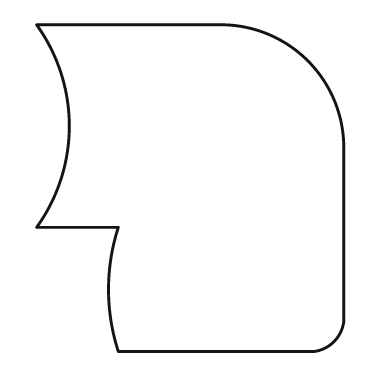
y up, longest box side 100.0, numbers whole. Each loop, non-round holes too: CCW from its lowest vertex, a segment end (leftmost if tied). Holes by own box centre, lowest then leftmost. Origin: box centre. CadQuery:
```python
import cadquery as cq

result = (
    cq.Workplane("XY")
    .moveTo(-22.0, -50.0)
    .lineTo(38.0, -50.0)
    .threePointArc((44.0, -47.0), (47.0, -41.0))
    .lineTo(47.0, 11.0)
    .threePointArc((36.0, 39.0), (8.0, 50.0))
    .lineTo(-47.0, 50.0)
    .threePointArc((-37.0, 19.0), (-47.0, -12.0))
    .lineTo(-22.0, -12.0)
    .threePointArc((-25.0, -31.0), (-22.0, -50.0))
    .close()
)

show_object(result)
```